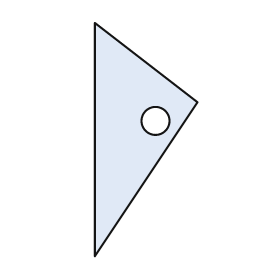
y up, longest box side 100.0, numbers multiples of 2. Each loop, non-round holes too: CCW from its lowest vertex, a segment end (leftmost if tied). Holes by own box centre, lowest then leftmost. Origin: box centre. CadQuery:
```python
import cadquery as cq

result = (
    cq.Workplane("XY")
    .moveTo(-22.0, -50.0)
    .lineTo(22.0, 16.0)
    .lineTo(-22.0, 50.0)
    .close()
    .moveTo(4.0, 8.0)
    .circle(6.0)
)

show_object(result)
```